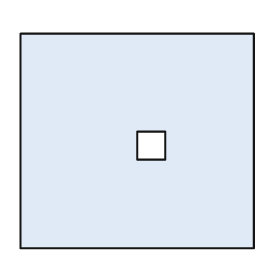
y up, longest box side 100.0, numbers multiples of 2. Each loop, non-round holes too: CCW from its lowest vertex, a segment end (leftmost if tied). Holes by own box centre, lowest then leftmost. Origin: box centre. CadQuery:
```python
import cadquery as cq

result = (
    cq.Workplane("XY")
    .moveTo(-50.0, -46.0)
    .lineTo(50.0, -46.0)
    .lineTo(50.0, 46.0)
    .lineTo(-50.0, 46.0)
    .close()
    .moveTo(0.0, -8.0)
    .lineTo(12.0, -8.0)
    .lineTo(12.0, 4.0)
    .lineTo(0.0, 4.0)
    .close()
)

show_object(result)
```